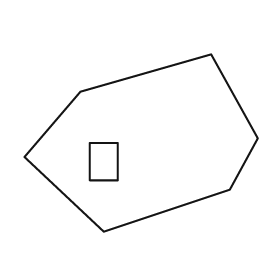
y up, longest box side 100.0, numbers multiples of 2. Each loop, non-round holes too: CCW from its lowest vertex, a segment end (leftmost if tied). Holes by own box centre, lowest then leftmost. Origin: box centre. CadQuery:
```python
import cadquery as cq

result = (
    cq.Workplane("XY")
    .moveTo(-16.0, -38.0)
    .lineTo(38.0, -20.0)
    .lineTo(50.0, 2.0)
    .lineTo(30.0, 38.0)
    .lineTo(-26.0, 22.0)
    .lineTo(-50.0, -6.0)
    .close()
    .moveTo(-22.0, -16.0)
    .lineTo(-10.0, -16.0)
    .lineTo(-10.0, 0.0)
    .lineTo(-22.0, 0.0)
    .close()
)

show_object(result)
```